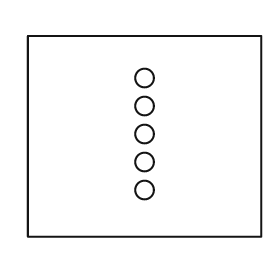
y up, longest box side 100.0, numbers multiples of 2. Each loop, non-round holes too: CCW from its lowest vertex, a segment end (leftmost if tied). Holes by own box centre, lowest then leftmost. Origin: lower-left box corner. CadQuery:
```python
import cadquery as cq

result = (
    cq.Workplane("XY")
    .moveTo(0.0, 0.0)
    .lineTo(100.0, 0.0)
    .lineTo(100.0, 86.0)
    .lineTo(0.0, 86.0)
    .close()
    .moveTo(50.0, 20.0)
    .circle(4.0)
    .moveTo(50.0, 32.0)
    .circle(4.0)
    .moveTo(50.0, 44.0)
    .circle(4.0)
    .moveTo(50.0, 56.0)
    .circle(4.0)
    .moveTo(50.0, 68.0)
    .circle(4.0)
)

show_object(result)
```